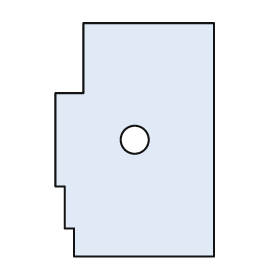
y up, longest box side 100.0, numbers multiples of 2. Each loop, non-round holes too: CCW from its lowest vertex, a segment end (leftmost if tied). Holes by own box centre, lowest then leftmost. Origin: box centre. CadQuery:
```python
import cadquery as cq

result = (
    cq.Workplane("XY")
    .moveTo(-26.0, -50.0)
    .lineTo(34.0, -50.0)
    .lineTo(34.0, 50.0)
    .lineTo(-22.0, 50.0)
    .lineTo(-22.0, 20.0)
    .lineTo(-34.0, 20.0)
    .lineTo(-34.0, -20.0)
    .lineTo(-30.0, -20.0)
    .lineTo(-30.0, -38.0)
    .lineTo(-26.0, -38.0)
    .close()
    .moveTo(0.0, 0.0)
    .circle(6.0)
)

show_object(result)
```